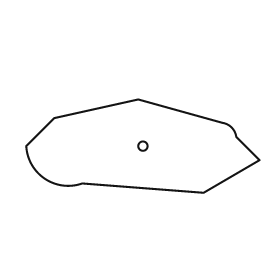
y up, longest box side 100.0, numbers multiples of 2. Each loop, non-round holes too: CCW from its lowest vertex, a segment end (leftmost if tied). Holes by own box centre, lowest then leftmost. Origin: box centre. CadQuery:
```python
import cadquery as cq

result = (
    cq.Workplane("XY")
    .moveTo(26.0, -20.0)
    .lineTo(50.0, -6.0)
    .lineTo(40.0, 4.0)
    .threePointArc((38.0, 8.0), (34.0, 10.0))
    .lineTo(-2.0, 20.0)
    .lineTo(-38.0, 12.0)
    .lineTo(-50.0, 0.0)
    .threePointArc((-42.0, -14.0), (-26.0, -16.0))
    .close()
    .moveTo(0.0, 0.0)
    .circle(2.0)
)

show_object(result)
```